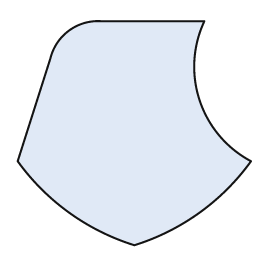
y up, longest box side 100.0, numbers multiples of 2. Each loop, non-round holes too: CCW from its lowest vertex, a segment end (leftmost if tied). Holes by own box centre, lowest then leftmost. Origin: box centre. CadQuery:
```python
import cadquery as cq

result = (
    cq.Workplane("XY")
    .moveTo(0.0, -48.0)
    .threePointArc((28.0, -34.0), (50.0, -12.0))
    .threePointArc((28.0, 14.0), (30.0, 48.0))
    .lineTo(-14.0, 48.0)
    .threePointArc((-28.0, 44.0), (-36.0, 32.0))
    .lineTo(-50.0, -12.0)
    .threePointArc((-28.0, -34.0), (0.0, -48.0))
    .close()
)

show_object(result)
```